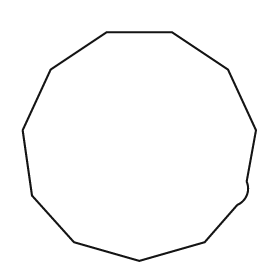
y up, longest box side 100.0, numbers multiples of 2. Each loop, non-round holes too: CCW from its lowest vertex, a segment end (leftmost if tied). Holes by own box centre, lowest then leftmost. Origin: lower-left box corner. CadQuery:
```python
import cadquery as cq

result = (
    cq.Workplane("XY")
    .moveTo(50.0, 0.0)
    .lineTo(78.0, 8.0)
    .lineTo(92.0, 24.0)
    .threePointArc((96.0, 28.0), (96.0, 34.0))
    .lineTo(100.0, 56.0)
    .lineTo(88.0, 82.0)
    .lineTo(64.0, 98.0)
    .lineTo(36.0, 98.0)
    .lineTo(12.0, 82.0)
    .lineTo(0.0, 56.0)
    .lineTo(4.0, 28.0)
    .lineTo(22.0, 8.0)
    .close()
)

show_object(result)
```